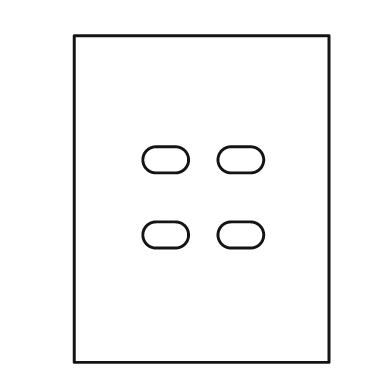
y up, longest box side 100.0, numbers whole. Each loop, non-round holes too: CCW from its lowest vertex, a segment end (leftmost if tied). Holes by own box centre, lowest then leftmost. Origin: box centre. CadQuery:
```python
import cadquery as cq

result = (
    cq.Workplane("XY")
    .moveTo(-39.0, -50.0)
    .lineTo(39.0, -50.0)
    .lineTo(39.0, 50.0)
    .lineTo(-39.0, 50.0)
    .close()
    .moveTo(-14.0, -15.0)
    .lineTo(-8.0, -15.0)
    .threePointArc((-4.0, -11.0), (-8.0, -7.0))
    .lineTo(-14.0, -7.0)
    .threePointArc((-18.0, -11.0), (-14.0, -15.0))
    .close()
    .moveTo(9.0, -15.0)
    .lineTo(15.0, -15.0)
    .threePointArc((19.0, -11.0), (15.0, -7.0))
    .lineTo(9.0, -7.0)
    .threePointArc((5.0, -11.0), (9.0, -15.0))
    .close()
    .moveTo(-14.0, 8.0)
    .lineTo(-8.0, 8.0)
    .threePointArc((-4.0, 12.0), (-8.0, 16.0))
    .lineTo(-14.0, 16.0)
    .threePointArc((-18.0, 12.0), (-14.0, 8.0))
    .close()
    .moveTo(9.0, 8.0)
    .lineTo(15.0, 8.0)
    .threePointArc((19.0, 12.0), (15.0, 16.0))
    .lineTo(9.0, 16.0)
    .threePointArc((5.0, 12.0), (9.0, 8.0))
    .close()
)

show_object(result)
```